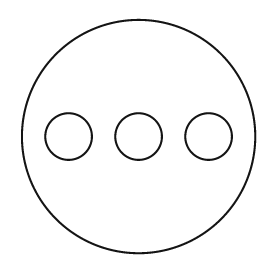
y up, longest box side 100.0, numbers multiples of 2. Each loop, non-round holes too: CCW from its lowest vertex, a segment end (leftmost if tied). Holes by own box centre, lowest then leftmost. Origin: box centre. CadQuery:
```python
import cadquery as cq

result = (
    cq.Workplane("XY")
    .moveTo(0.0, 0.0)
    .circle(50.0)
    .moveTo(-30.0, 0.0)
    .circle(10.0)
    .moveTo(0.0, 0.0)
    .circle(10.0)
    .moveTo(30.0, 0.0)
    .circle(10.0)
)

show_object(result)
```